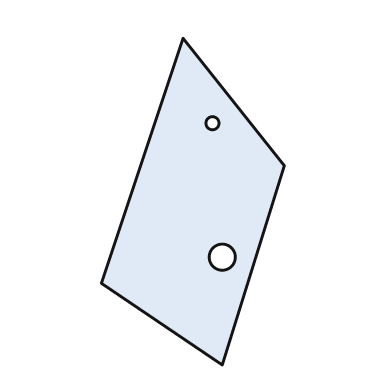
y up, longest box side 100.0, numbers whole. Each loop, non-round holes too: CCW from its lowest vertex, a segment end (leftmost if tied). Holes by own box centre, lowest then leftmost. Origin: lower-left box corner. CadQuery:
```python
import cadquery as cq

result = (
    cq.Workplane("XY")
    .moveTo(37.0, 0.0)
    .lineTo(56.0, 61.0)
    .lineTo(25.0, 100.0)
    .lineTo(0.0, 25.0)
    .close()
    .moveTo(37.0, 33.0)
    .circle(4.0)
    .moveTo(34.0, 74.0)
    .circle(2.0)
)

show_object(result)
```